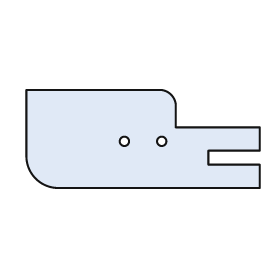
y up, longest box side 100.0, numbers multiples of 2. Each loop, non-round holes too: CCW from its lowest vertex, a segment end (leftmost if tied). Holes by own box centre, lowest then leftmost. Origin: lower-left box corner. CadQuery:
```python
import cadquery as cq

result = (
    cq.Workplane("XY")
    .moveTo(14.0, 0.0)
    .lineTo(100.0, 0.0)
    .lineTo(100.0, 10.0)
    .lineTo(78.0, 10.0)
    .lineTo(78.0, 16.0)
    .lineTo(100.0, 16.0)
    .lineTo(100.0, 26.0)
    .lineTo(64.0, 26.0)
    .lineTo(64.0, 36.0)
    .threePointArc((62.0, 40.0), (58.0, 42.0))
    .lineTo(0.0, 42.0)
    .lineTo(0.0, 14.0)
    .threePointArc((4.0, 4.0), (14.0, 0.0))
    .close()
    .moveTo(42.0, 20.0)
    .circle(2.0)
    .moveTo(58.0, 20.0)
    .circle(2.0)
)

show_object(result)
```